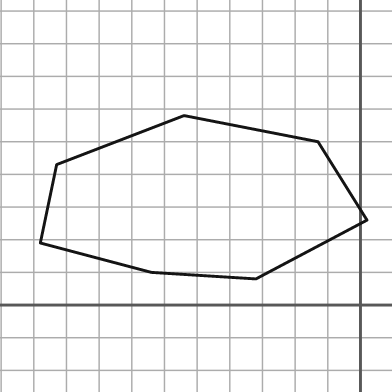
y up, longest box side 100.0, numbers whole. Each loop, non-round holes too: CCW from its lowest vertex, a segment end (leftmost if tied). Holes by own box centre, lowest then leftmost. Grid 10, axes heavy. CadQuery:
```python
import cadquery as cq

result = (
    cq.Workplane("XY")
    .moveTo(-32.0, 8.0)
    .lineTo(2.0, 26.0)
    .lineTo(-13.0, 50.0)
    .lineTo(-54.0, 58.0)
    .lineTo(-93.0, 43.0)
    .lineTo(-98.0, 19.0)
    .lineTo(-64.0, 10.0)
    .close()
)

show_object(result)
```